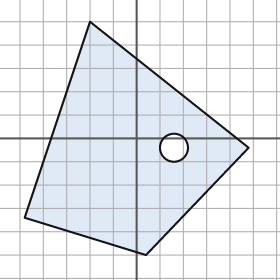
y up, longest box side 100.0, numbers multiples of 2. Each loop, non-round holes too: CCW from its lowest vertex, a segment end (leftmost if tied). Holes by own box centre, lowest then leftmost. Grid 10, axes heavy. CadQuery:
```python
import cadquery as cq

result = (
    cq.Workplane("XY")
    .moveTo(4.0, -50.0)
    .lineTo(48.0, -4.0)
    .lineTo(-20.0, 50.0)
    .lineTo(-48.0, -34.0)
    .close()
    .moveTo(16.0, -4.0)
    .circle(6.0)
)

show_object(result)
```